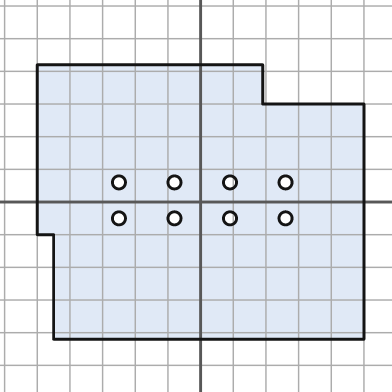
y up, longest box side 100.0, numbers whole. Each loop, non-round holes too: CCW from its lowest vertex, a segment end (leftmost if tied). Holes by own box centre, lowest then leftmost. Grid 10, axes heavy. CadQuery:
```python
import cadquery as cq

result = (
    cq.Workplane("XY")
    .moveTo(-45.0, -42.0)
    .lineTo(50.0, -42.0)
    .lineTo(50.0, 30.0)
    .lineTo(19.0, 30.0)
    .lineTo(19.0, 42.0)
    .lineTo(-50.0, 42.0)
    .lineTo(-50.0, -10.0)
    .lineTo(-45.0, -10.0)
    .close()
    .moveTo(-25.0, -5.0)
    .circle(2.0)
    .moveTo(-8.0, -5.0)
    .circle(2.0)
    .moveTo(9.0, -5.0)
    .circle(2.0)
    .moveTo(26.0, -5.0)
    .circle(2.0)
    .moveTo(-25.0, 6.0)
    .circle(2.0)
    .moveTo(-8.0, 6.0)
    .circle(2.0)
    .moveTo(9.0, 6.0)
    .circle(2.0)
    .moveTo(26.0, 6.0)
    .circle(2.0)
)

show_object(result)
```